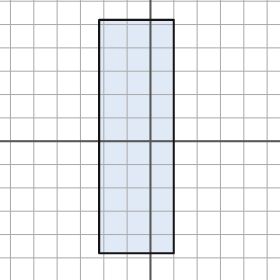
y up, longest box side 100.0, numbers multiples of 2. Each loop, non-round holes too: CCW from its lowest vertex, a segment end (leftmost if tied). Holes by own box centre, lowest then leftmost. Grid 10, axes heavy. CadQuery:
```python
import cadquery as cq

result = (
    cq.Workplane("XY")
    .moveTo(-22.0, -48.0)
    .lineTo(10.0, -48.0)
    .lineTo(10.0, 52.0)
    .lineTo(-22.0, 52.0)
    .close()
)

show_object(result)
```